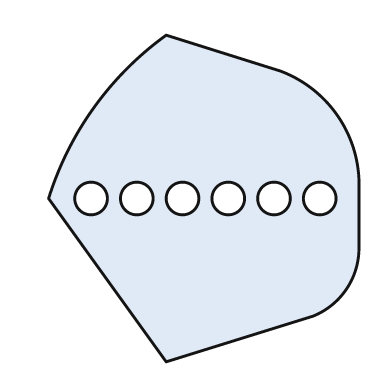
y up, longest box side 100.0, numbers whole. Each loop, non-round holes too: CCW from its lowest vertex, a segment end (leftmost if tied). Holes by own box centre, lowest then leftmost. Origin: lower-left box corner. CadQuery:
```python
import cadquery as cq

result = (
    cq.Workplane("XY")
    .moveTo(36.0, 0.0)
    .lineTo(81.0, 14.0)
    .threePointArc((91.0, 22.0), (95.0, 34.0))
    .lineTo(95.0, 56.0)
    .threePointArc((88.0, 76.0), (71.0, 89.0))
    .lineTo(36.0, 100.0)
    .threePointArc((14.0, 78.0), (0.0, 50.0))
    .close()
    .moveTo(13.0, 50.0)
    .circle(5.0)
    .moveTo(27.0, 50.0)
    .circle(5.0)
    .moveTo(41.0, 50.0)
    .circle(5.0)
    .moveTo(55.0, 50.0)
    .circle(5.0)
    .moveTo(69.0, 50.0)
    .circle(5.0)
    .moveTo(83.0, 50.0)
    .circle(5.0)
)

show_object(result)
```